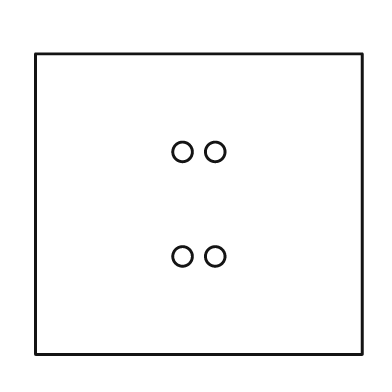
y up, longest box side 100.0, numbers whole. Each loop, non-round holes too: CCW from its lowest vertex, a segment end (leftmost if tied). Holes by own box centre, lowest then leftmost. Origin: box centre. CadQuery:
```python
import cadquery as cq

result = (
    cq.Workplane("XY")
    .moveTo(-50.0, -46.0)
    .lineTo(50.0, -46.0)
    .lineTo(50.0, 46.0)
    .lineTo(-50.0, 46.0)
    .close()
    .moveTo(-5.0, -16.0)
    .circle(3.0)
    .moveTo(5.0, -16.0)
    .circle(3.0)
    .moveTo(-5.0, 16.0)
    .circle(3.0)
    .moveTo(5.0, 16.0)
    .circle(3.0)
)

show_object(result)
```